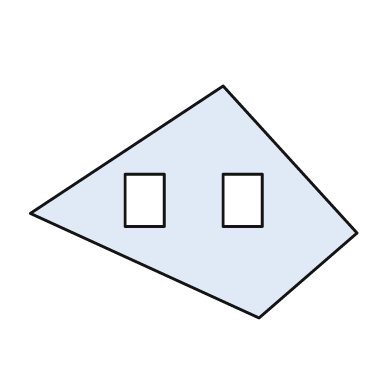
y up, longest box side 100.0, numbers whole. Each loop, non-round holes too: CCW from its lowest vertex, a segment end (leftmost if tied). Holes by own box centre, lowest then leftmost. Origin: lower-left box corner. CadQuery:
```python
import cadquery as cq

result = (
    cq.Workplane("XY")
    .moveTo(70.0, 0.0)
    .lineTo(100.0, 26.0)
    .lineTo(59.0, 71.0)
    .lineTo(0.0, 32.0)
    .close()
    .moveTo(29.0, 28.0)
    .lineTo(41.0, 28.0)
    .lineTo(41.0, 44.0)
    .lineTo(29.0, 44.0)
    .close()
    .moveTo(59.0, 28.0)
    .lineTo(71.0, 28.0)
    .lineTo(71.0, 44.0)
    .lineTo(59.0, 44.0)
    .close()
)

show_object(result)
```